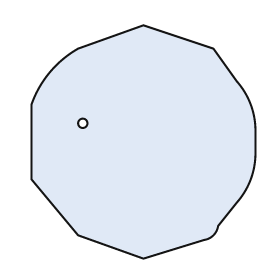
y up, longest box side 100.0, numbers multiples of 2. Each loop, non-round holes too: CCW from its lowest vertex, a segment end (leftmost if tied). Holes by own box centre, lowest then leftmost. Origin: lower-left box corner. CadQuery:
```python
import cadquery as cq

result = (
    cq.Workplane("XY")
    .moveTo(48.0, 0.0)
    .lineTo(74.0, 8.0)
    .threePointArc((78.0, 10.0), (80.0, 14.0))
    .lineTo(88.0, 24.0)
    .threePointArc((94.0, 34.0), (96.0, 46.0))
    .lineTo(96.0, 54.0)
    .threePointArc((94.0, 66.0), (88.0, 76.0))
    .lineTo(78.0, 90.0)
    .lineTo(48.0, 100.0)
    .lineTo(20.0, 90.0)
    .threePointArc((8.0, 80.0), (0.0, 66.0))
    .lineTo(0.0, 34.0)
    .lineTo(20.0, 10.0)
    .close()
    .moveTo(22.0, 58.0)
    .circle(2.0)
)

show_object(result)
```